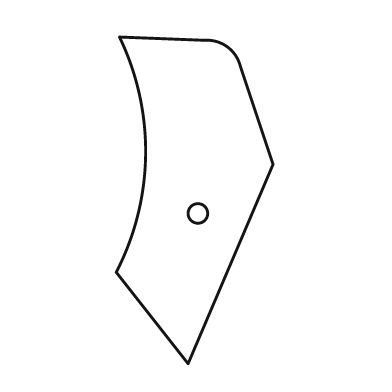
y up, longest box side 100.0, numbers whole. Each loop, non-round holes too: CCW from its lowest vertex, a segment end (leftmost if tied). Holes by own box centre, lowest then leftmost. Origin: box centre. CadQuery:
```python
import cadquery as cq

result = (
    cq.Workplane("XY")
    .moveTo(-2.0, -50.0)
    .lineTo(24.0, 11.0)
    .lineTo(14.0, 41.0)
    .threePointArc((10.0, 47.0), (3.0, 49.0))
    .lineTo(-23.0, 50.0)
    .threePointArc((-15.0, 14.0), (-24.0, -22.0))
    .close()
    .moveTo(1.0, -4.0)
    .circle(3.0)
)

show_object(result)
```